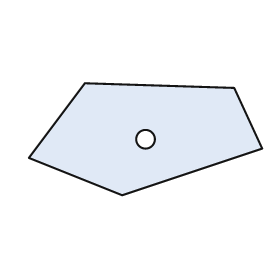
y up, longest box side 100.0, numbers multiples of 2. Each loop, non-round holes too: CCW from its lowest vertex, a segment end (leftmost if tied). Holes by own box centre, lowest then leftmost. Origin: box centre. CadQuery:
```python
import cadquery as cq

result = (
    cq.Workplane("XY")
    .moveTo(-10.0, -24.0)
    .lineTo(50.0, -4.0)
    .lineTo(38.0, 22.0)
    .lineTo(-26.0, 24.0)
    .lineTo(-50.0, -8.0)
    .close()
    .moveTo(0.0, 0.0)
    .circle(4.0)
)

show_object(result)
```